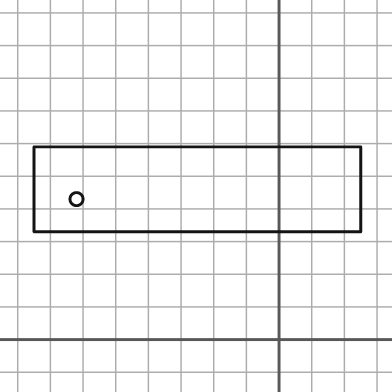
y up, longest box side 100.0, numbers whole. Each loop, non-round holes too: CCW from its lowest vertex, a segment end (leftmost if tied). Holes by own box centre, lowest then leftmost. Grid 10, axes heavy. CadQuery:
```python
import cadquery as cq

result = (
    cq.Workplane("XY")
    .moveTo(-75.0, 33.0)
    .lineTo(25.0, 33.0)
    .lineTo(25.0, 59.0)
    .lineTo(-75.0, 59.0)
    .close()
    .moveTo(-62.0, 43.0)
    .circle(2.0)
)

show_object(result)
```